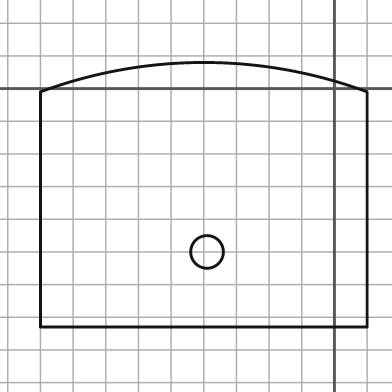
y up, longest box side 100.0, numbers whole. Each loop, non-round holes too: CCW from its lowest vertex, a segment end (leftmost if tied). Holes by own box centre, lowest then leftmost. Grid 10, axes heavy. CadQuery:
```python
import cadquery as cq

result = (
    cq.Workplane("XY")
    .moveTo(-90.0, -73.0)
    .lineTo(10.0, -73.0)
    .lineTo(10.0, -1.0)
    .threePointArc((-40.0, 8.0), (-90.0, -1.0))
    .close()
    .moveTo(-39.0, -50.0)
    .circle(5.0)
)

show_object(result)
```